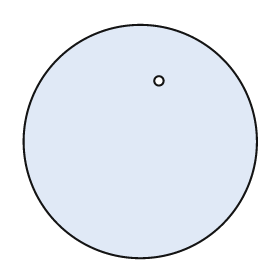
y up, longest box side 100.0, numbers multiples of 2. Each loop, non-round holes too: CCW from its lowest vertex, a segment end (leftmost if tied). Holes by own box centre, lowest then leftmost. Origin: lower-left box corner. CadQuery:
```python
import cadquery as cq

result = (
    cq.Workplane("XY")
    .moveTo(50.0, 50.0)
    .circle(50.0)
    .moveTo(58.0, 76.0)
    .circle(2.0)
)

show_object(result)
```